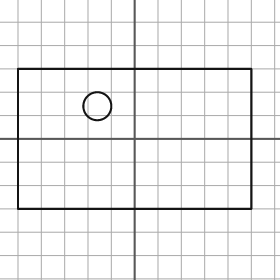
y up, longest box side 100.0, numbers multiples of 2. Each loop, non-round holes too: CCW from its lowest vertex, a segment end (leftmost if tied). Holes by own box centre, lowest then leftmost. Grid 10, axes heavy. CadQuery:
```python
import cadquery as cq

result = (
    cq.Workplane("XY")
    .moveTo(-50.0, -30.0)
    .lineTo(50.0, -30.0)
    .lineTo(50.0, 30.0)
    .lineTo(-50.0, 30.0)
    .close()
    .moveTo(-16.0, 14.0)
    .circle(6.0)
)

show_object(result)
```